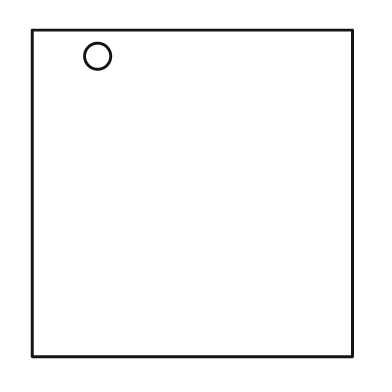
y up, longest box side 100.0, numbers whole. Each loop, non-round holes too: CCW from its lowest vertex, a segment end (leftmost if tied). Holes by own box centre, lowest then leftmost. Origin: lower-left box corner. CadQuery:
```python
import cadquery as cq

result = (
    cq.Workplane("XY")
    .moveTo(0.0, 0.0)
    .lineTo(98.0, 0.0)
    .lineTo(98.0, 100.0)
    .lineTo(0.0, 100.0)
    .close()
    .moveTo(20.0, 92.0)
    .circle(4.0)
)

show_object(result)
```